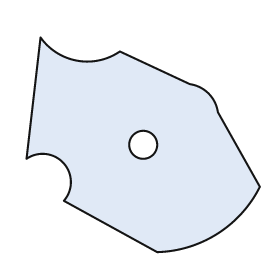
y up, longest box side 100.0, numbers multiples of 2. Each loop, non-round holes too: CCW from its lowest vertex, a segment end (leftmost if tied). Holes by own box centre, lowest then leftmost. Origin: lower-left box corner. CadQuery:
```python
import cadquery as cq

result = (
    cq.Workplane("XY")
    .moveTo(56.0, 0.0)
    .threePointArc((82.0, 8.0), (100.0, 28.0))
    .lineTo(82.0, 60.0)
    .threePointArc((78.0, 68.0), (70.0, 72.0))
    .lineTo(40.0, 86.0)
    .threePointArc((22.0, 82.0), (6.0, 92.0))
    .lineTo(0.0, 40.0)
    .threePointArc((16.0, 38.0), (16.0, 22.0))
    .close()
    .moveTo(50.0, 46.0)
    .circle(6.0)
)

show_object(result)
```